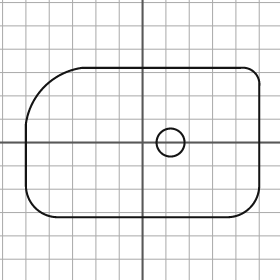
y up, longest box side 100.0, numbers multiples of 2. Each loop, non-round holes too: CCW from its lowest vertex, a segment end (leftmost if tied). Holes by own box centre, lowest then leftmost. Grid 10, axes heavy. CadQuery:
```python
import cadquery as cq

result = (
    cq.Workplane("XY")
    .moveTo(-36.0, -32.0)
    .lineTo(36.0, -32.0)
    .threePointArc((46.0, -28.0), (50.0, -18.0))
    .lineTo(50.0, 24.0)
    .threePointArc((48.0, 30.0), (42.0, 32.0))
    .lineTo(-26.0, 32.0)
    .threePointArc((-42.0, 24.0), (-50.0, 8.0))
    .lineTo(-50.0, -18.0)
    .threePointArc((-46.0, -28.0), (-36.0, -32.0))
    .close()
    .moveTo(12.0, 0.0)
    .circle(6.0)
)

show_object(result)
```